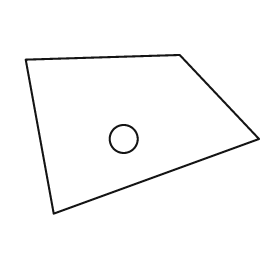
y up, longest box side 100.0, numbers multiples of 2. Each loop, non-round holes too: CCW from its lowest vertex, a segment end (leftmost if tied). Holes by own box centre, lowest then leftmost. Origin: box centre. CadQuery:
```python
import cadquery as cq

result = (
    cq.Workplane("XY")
    .moveTo(-38.0, -34.0)
    .lineTo(50.0, -2.0)
    .lineTo(16.0, 34.0)
    .lineTo(-50.0, 32.0)
    .close()
    .moveTo(-8.0, -2.0)
    .circle(6.0)
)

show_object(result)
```